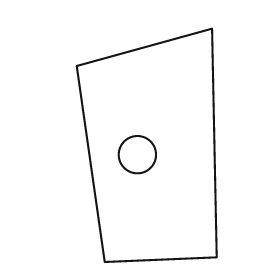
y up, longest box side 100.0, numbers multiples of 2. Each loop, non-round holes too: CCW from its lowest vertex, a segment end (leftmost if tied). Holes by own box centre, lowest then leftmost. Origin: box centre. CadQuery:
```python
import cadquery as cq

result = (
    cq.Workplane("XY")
    .moveTo(-18.0, -50.0)
    .lineTo(30.0, -48.0)
    .lineTo(28.0, 50.0)
    .lineTo(-30.0, 34.0)
    .close()
    .moveTo(-4.0, -4.0)
    .circle(8.0)
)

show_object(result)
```